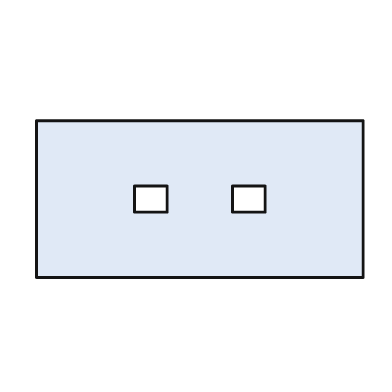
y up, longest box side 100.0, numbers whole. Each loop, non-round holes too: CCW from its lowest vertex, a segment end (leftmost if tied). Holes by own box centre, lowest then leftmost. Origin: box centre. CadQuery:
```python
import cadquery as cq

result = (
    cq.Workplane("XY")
    .moveTo(-50.0, -24.0)
    .lineTo(50.0, -24.0)
    .lineTo(50.0, 24.0)
    .lineTo(-50.0, 24.0)
    .close()
    .moveTo(-20.0, -4.0)
    .lineTo(-10.0, -4.0)
    .lineTo(-10.0, 4.0)
    .lineTo(-20.0, 4.0)
    .close()
    .moveTo(10.0, -4.0)
    .lineTo(20.0, -4.0)
    .lineTo(20.0, 4.0)
    .lineTo(10.0, 4.0)
    .close()
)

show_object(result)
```